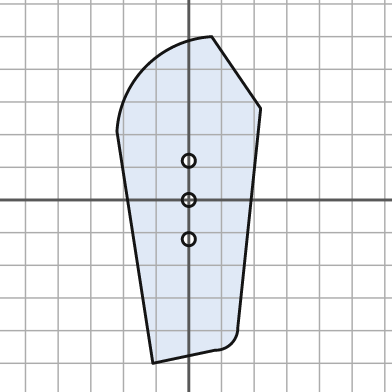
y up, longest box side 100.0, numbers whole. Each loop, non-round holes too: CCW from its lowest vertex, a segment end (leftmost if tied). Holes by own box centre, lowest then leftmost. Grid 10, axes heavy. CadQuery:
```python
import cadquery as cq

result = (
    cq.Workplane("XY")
    .moveTo(-11.0, -50.0)
    .lineTo(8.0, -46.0)
    .threePointArc((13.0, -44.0), (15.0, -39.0))
    .lineTo(22.0, 28.0)
    .lineTo(7.0, 50.0)
    .threePointArc((-13.0, 41.0), (-22.0, 21.0))
    .close()
    .moveTo(0.0, -12.0)
    .circle(2.0)
    .moveTo(0.0, 0.0)
    .circle(2.0)
    .moveTo(0.0, 12.0)
    .circle(2.0)
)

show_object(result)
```